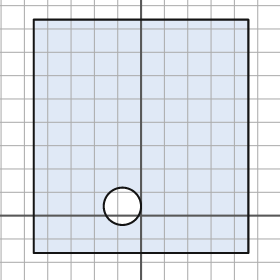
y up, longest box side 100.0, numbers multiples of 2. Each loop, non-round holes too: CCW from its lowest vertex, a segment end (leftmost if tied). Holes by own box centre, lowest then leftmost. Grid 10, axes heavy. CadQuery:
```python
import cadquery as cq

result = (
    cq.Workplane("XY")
    .moveTo(-46.0, -16.0)
    .lineTo(46.0, -16.0)
    .lineTo(46.0, 84.0)
    .lineTo(-46.0, 84.0)
    .close()
    .moveTo(-8.0, 4.0)
    .circle(8.0)
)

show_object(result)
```